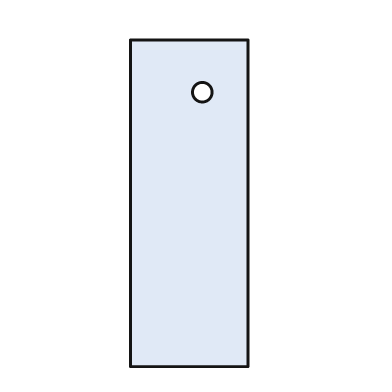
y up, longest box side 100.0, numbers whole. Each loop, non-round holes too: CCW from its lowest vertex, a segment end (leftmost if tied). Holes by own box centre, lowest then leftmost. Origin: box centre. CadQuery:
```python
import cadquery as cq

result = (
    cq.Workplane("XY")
    .moveTo(-18.0, -50.0)
    .lineTo(18.0, -50.0)
    .lineTo(18.0, 50.0)
    .lineTo(-18.0, 50.0)
    .close()
    .moveTo(4.0, 34.0)
    .circle(3.0)
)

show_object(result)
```